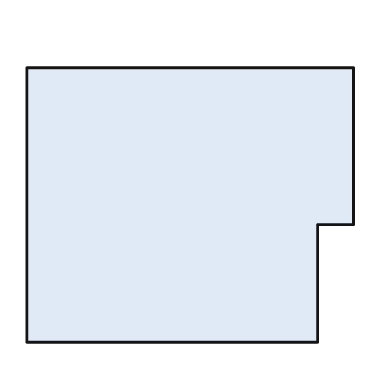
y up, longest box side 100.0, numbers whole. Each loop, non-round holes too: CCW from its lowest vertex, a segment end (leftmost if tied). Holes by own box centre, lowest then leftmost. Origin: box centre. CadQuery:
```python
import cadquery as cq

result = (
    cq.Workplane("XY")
    .moveTo(-50.0, -42.0)
    .lineTo(39.0, -42.0)
    .lineTo(39.0, -6.0)
    .lineTo(50.0, -6.0)
    .lineTo(50.0, 42.0)
    .lineTo(-50.0, 42.0)
    .close()
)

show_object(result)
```